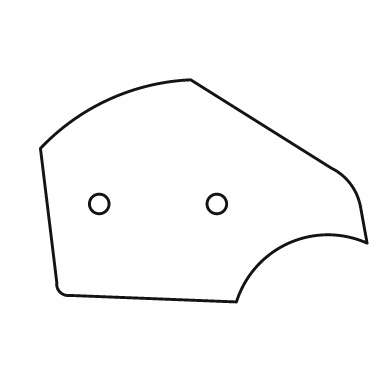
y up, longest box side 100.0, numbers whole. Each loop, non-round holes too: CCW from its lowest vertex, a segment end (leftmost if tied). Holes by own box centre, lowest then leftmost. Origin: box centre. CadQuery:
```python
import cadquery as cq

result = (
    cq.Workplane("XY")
    .moveTo(10.0, -34.0)
    .threePointArc((26.0, -16.0), (50.0, -16.0))
    .lineTo(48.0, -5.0)
    .threePointArc((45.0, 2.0), (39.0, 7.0))
    .lineTo(-4.0, 34.0)
    .threePointArc((-29.0, 28.0), (-50.0, 13.0))
    .lineTo(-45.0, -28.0)
    .threePointArc((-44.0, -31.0), (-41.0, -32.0))
    .close()
    .moveTo(-32.0, -4.0)
    .circle(3.0)
    .moveTo(4.0, -4.0)
    .circle(3.0)
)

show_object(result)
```